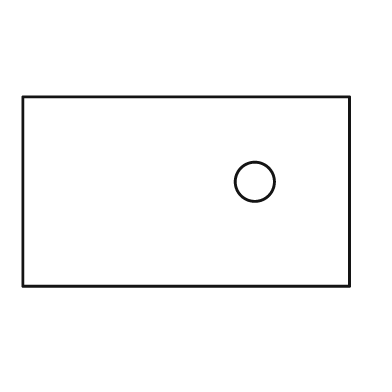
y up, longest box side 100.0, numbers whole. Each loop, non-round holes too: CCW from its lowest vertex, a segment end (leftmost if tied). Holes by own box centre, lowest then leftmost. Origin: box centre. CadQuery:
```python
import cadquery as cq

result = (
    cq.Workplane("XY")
    .moveTo(-50.0, -29.0)
    .lineTo(50.0, -29.0)
    .lineTo(50.0, 29.0)
    .lineTo(-50.0, 29.0)
    .close()
    .moveTo(21.0, 3.0)
    .circle(6.0)
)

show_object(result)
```